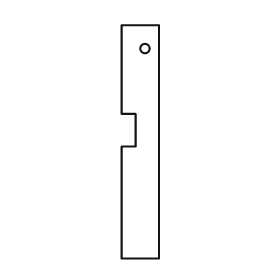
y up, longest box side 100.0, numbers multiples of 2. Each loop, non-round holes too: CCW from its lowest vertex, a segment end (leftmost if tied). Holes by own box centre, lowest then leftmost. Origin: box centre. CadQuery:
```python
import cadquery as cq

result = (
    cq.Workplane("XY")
    .moveTo(-8.0, -50.0)
    .lineTo(8.0, -50.0)
    .lineTo(8.0, 50.0)
    .lineTo(-8.0, 50.0)
    .lineTo(-8.0, 12.0)
    .lineTo(-2.0, 12.0)
    .lineTo(-2.0, -2.0)
    .lineTo(-8.0, -2.0)
    .close()
    .moveTo(2.0, 40.0)
    .circle(2.0)
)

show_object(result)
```